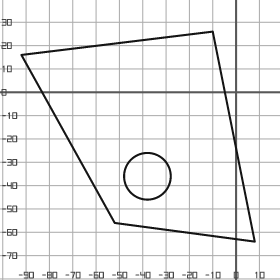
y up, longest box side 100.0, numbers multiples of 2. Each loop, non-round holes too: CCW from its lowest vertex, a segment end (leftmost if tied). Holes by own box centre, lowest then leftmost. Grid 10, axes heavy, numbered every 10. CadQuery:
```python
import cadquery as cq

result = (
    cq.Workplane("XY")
    .moveTo(8.0, -64.0)
    .lineTo(-10.0, 26.0)
    .lineTo(-92.0, 16.0)
    .lineTo(-52.0, -56.0)
    .close()
    .moveTo(-38.0, -36.0)
    .circle(10.0)
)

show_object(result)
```